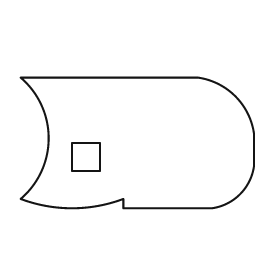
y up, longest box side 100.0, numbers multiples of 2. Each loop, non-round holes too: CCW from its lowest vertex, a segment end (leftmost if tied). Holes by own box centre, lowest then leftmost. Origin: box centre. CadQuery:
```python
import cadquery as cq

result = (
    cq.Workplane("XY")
    .moveTo(-6.0, -28.0)
    .lineTo(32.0, -28.0)
    .threePointArc((44.0, -22.0), (50.0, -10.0))
    .lineTo(50.0, 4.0)
    .threePointArc((42.0, 20.0), (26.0, 28.0))
    .lineTo(-50.0, 28.0)
    .threePointArc((-38.0, 2.0), (-50.0, -24.0))
    .threePointArc((-28.0, -28.0), (-6.0, -24.0))
    .close()
    .moveTo(-28.0, -12.0)
    .lineTo(-16.0, -12.0)
    .lineTo(-16.0, 0.0)
    .lineTo(-28.0, 0.0)
    .close()
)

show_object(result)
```